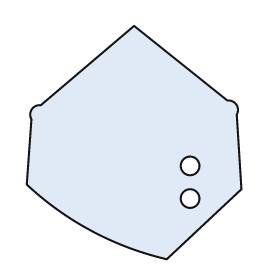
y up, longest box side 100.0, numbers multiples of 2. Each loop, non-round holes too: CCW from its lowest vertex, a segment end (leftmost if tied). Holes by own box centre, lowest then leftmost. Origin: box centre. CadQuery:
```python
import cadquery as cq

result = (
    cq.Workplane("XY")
    .moveTo(14.0, -50.0)
    .lineTo(46.0, -20.0)
    .lineTo(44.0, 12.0)
    .threePointArc((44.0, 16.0), (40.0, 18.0))
    .lineTo(0.0, 50.0)
    .lineTo(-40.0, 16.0)
    .threePointArc((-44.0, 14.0), (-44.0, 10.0))
    .lineTo(-46.0, -18.0)
    .threePointArc((-18.0, -38.0), (14.0, -50.0))
    .close()
    .moveTo(24.0, -24.0)
    .circle(4.0)
    .moveTo(24.0, -10.0)
    .circle(4.0)
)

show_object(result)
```